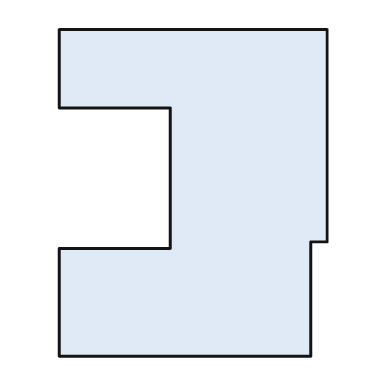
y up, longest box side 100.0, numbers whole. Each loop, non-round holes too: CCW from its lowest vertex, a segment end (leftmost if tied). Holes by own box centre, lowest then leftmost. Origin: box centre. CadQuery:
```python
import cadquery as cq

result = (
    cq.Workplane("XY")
    .moveTo(-41.0, -50.0)
    .lineTo(36.0, -50.0)
    .lineTo(36.0, -15.0)
    .lineTo(41.0, -15.0)
    .lineTo(41.0, 50.0)
    .lineTo(-41.0, 50.0)
    .lineTo(-41.0, 26.0)
    .lineTo(-7.0, 26.0)
    .lineTo(-7.0, -17.0)
    .lineTo(-41.0, -17.0)
    .close()
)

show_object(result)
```